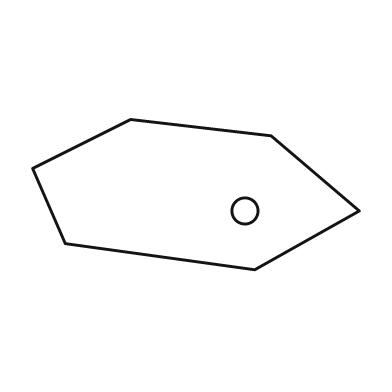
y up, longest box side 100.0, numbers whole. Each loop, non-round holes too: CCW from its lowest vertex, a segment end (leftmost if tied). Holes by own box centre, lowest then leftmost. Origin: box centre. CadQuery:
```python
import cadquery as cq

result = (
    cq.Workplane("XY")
    .moveTo(18.0, -23.0)
    .lineTo(50.0, -5.0)
    .lineTo(23.0, 18.0)
    .lineTo(-20.0, 23.0)
    .lineTo(-50.0, 8.0)
    .lineTo(-40.0, -15.0)
    .close()
    .moveTo(15.0, -5.0)
    .circle(4.0)
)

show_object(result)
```